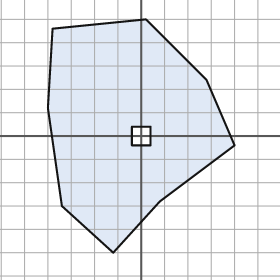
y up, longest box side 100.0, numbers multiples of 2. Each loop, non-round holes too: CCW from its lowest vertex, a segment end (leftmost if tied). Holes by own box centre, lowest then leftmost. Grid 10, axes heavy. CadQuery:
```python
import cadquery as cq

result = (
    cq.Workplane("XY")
    .moveTo(-12.0, -50.0)
    .lineTo(8.0, -28.0)
    .lineTo(40.0, -4.0)
    .lineTo(28.0, 24.0)
    .lineTo(2.0, 50.0)
    .lineTo(-38.0, 46.0)
    .lineTo(-40.0, 12.0)
    .lineTo(-34.0, -30.0)
    .close()
    .moveTo(-4.0, -4.0)
    .lineTo(4.0, -4.0)
    .lineTo(4.0, 4.0)
    .lineTo(-4.0, 4.0)
    .close()
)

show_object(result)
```